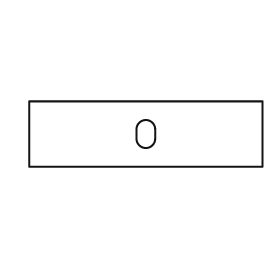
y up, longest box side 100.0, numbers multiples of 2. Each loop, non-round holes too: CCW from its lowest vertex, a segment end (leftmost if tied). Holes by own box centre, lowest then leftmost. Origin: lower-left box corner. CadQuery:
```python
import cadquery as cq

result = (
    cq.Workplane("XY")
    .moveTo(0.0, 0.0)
    .lineTo(100.0, 0.0)
    .lineTo(100.0, 28.0)
    .lineTo(0.0, 28.0)
    .close()
    .moveTo(46.0, 12.0)
    .threePointArc((50.0, 8.0), (54.0, 12.0))
    .lineTo(54.0, 16.0)
    .threePointArc((50.0, 20.0), (46.0, 16.0))
    .close()
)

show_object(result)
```